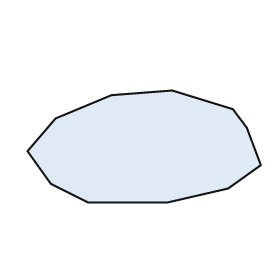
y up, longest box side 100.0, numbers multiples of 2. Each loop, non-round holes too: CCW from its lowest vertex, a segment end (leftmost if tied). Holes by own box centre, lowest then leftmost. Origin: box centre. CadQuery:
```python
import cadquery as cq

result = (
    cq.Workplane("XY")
    .moveTo(-24.0, -24.0)
    .lineTo(10.0, -24.0)
    .lineTo(36.0, -18.0)
    .lineTo(50.0, -8.0)
    .lineTo(44.0, 8.0)
    .lineTo(38.0, 16.0)
    .lineTo(12.0, 24.0)
    .lineTo(-14.0, 22.0)
    .lineTo(-38.0, 12.0)
    .lineTo(-50.0, -2.0)
    .lineTo(-40.0, -16.0)
    .close()
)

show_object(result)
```